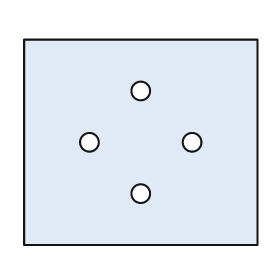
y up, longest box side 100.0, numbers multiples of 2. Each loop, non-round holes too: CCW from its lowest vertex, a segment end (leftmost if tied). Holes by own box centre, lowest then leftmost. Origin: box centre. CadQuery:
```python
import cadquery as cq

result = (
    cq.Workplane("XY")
    .moveTo(-50.0, -44.0)
    .lineTo(50.0, -44.0)
    .lineTo(50.0, 44.0)
    .lineTo(-50.0, 44.0)
    .close()
    .moveTo(0.0, -22.0)
    .circle(4.0)
    .moveTo(-22.0, 0.0)
    .circle(4.0)
    .moveTo(22.0, 0.0)
    .circle(4.0)
    .moveTo(0.0, 22.0)
    .circle(4.0)
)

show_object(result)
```